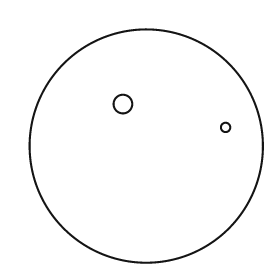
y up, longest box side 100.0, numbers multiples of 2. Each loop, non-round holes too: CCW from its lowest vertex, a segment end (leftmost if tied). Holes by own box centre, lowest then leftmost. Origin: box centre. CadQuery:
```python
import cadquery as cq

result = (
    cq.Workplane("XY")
    .moveTo(0.0, 0.0)
    .circle(50.0)
    .moveTo(34.0, 8.0)
    .circle(2.0)
    .moveTo(-10.0, 18.0)
    .circle(4.0)
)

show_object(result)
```